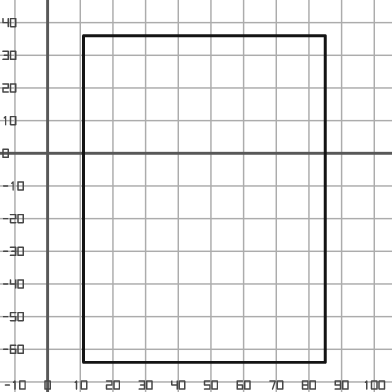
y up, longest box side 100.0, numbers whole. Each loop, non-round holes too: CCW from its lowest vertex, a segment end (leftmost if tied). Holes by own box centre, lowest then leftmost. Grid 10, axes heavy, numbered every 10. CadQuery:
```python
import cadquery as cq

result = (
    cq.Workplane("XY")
    .moveTo(11.0, -64.0)
    .lineTo(85.0, -64.0)
    .lineTo(85.0, 36.0)
    .lineTo(11.0, 36.0)
    .close()
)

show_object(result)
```